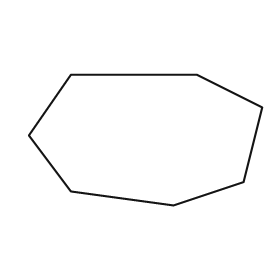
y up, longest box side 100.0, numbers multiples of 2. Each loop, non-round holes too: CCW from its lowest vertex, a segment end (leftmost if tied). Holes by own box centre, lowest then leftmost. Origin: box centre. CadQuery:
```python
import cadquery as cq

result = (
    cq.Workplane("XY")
    .moveTo(12.0, -28.0)
    .lineTo(42.0, -18.0)
    .lineTo(50.0, 14.0)
    .lineTo(22.0, 28.0)
    .lineTo(-32.0, 28.0)
    .lineTo(-50.0, 2.0)
    .lineTo(-32.0, -22.0)
    .close()
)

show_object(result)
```